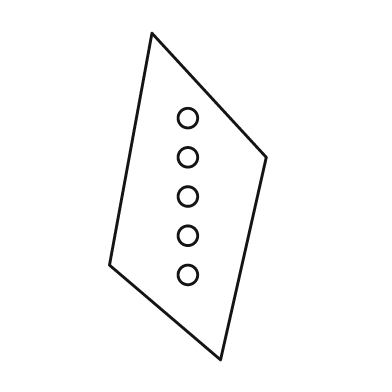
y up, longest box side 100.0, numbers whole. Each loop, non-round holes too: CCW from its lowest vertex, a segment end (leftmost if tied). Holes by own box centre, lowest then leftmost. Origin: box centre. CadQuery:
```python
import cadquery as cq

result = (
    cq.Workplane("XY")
    .moveTo(10.0, -50.0)
    .lineTo(24.0, 12.0)
    .lineTo(-11.0, 50.0)
    .lineTo(-24.0, -21.0)
    .close()
    .moveTo(0.0, -24.0)
    .circle(3.0)
    .moveTo(0.0, -12.0)
    .circle(3.0)
    .moveTo(0.0, 0.0)
    .circle(3.0)
    .moveTo(0.0, 12.0)
    .circle(3.0)
    .moveTo(0.0, 24.0)
    .circle(3.0)
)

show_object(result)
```